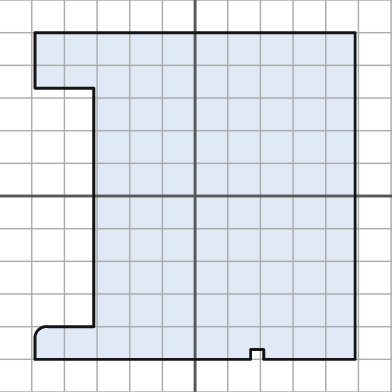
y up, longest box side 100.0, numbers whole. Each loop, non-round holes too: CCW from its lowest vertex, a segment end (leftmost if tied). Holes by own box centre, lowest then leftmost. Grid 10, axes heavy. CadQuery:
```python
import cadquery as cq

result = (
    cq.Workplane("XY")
    .moveTo(-49.0, -50.0)
    .lineTo(17.0, -50.0)
    .lineTo(17.0, -47.0)
    .lineTo(21.0, -47.0)
    .lineTo(21.0, -50.0)
    .lineTo(49.0, -50.0)
    .lineTo(49.0, 50.0)
    .lineTo(-49.0, 50.0)
    .lineTo(-49.0, 33.0)
    .lineTo(-31.0, 33.0)
    .lineTo(-31.0, -40.0)
    .lineTo(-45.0, -40.0)
    .threePointArc((-48.0, -41.0), (-49.0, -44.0))
    .close()
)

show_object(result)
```